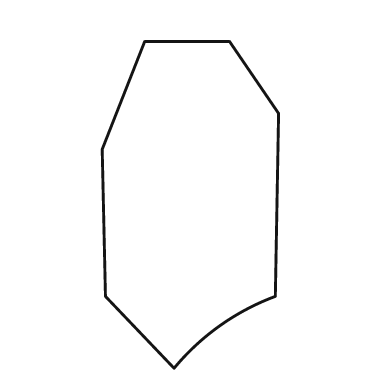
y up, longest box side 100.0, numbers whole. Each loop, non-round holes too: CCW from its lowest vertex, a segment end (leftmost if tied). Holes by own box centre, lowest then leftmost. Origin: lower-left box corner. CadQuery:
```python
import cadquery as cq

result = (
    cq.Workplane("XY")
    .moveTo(22.0, 0.0)
    .threePointArc((36.0, 13.0), (53.0, 22.0))
    .lineTo(54.0, 78.0)
    .lineTo(39.0, 100.0)
    .lineTo(13.0, 100.0)
    .lineTo(0.0, 67.0)
    .lineTo(1.0, 22.0)
    .close()
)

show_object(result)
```